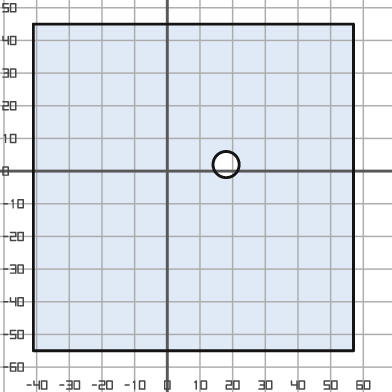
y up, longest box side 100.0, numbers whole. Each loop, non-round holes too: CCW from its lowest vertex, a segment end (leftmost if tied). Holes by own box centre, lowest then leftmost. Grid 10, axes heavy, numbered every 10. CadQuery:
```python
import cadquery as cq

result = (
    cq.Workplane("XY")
    .moveTo(-41.0, -55.0)
    .lineTo(57.0, -55.0)
    .lineTo(57.0, 45.0)
    .lineTo(-41.0, 45.0)
    .close()
    .moveTo(18.0, 2.0)
    .circle(4.0)
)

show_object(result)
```